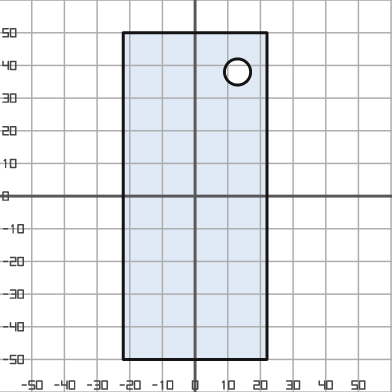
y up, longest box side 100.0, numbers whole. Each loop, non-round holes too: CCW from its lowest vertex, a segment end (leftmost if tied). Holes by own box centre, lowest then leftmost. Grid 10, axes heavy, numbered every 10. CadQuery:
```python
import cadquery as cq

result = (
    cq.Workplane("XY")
    .moveTo(-22.0, -50.0)
    .lineTo(22.0, -50.0)
    .lineTo(22.0, 50.0)
    .lineTo(-22.0, 50.0)
    .close()
    .moveTo(13.0, 38.0)
    .circle(4.0)
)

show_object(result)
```